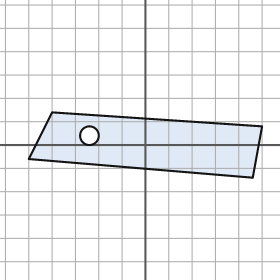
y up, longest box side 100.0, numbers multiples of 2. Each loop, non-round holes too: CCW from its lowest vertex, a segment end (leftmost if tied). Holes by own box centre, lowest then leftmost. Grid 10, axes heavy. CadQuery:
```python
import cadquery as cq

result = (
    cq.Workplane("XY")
    .moveTo(46.0, -14.0)
    .lineTo(50.0, 8.0)
    .lineTo(-40.0, 14.0)
    .lineTo(-50.0, -6.0)
    .close()
    .moveTo(-24.0, 4.0)
    .circle(4.0)
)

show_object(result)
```